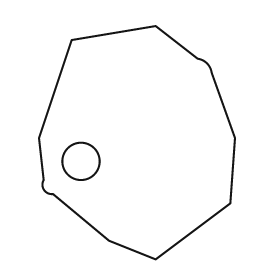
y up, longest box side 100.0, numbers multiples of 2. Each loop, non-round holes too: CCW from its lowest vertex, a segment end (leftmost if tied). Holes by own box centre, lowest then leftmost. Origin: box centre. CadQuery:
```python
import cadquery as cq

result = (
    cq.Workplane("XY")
    .moveTo(8.0, -50.0)
    .lineTo(40.0, -26.0)
    .lineTo(42.0, 2.0)
    .lineTo(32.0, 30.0)
    .threePointArc((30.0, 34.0), (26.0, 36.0))
    .lineTo(8.0, 50.0)
    .lineTo(-28.0, 44.0)
    .lineTo(-42.0, 2.0)
    .lineTo(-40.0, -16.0)
    .threePointArc((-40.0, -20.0), (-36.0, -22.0))
    .lineTo(-12.0, -42.0)
    .close()
    .moveTo(-24.0, -8.0)
    .circle(8.0)
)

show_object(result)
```